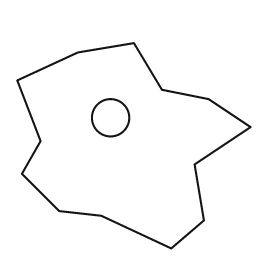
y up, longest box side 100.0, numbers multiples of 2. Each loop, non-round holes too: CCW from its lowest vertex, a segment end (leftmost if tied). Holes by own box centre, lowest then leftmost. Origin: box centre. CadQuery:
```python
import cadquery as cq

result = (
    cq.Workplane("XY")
    .moveTo(16.0, -44.0)
    .lineTo(30.0, -32.0)
    .lineTo(26.0, -8.0)
    .lineTo(50.0, 8.0)
    .lineTo(32.0, 20.0)
    .lineTo(12.0, 24.0)
    .lineTo(0.0, 44.0)
    .lineTo(-24.0, 40.0)
    .lineTo(-50.0, 28.0)
    .lineTo(-40.0, 2.0)
    .lineTo(-48.0, -12.0)
    .lineTo(-32.0, -28.0)
    .lineTo(-14.0, -30.0)
    .close()
    .moveTo(-10.0, 12.0)
    .circle(8.0)
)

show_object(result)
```